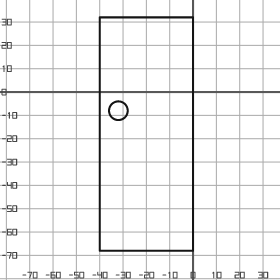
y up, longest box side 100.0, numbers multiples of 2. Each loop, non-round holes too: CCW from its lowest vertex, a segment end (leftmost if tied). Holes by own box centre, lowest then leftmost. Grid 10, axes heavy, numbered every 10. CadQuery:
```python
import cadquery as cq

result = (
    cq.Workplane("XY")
    .moveTo(-40.0, -68.0)
    .lineTo(0.0, -68.0)
    .lineTo(0.0, 32.0)
    .lineTo(-40.0, 32.0)
    .close()
    .moveTo(-32.0, -8.0)
    .circle(4.0)
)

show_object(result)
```